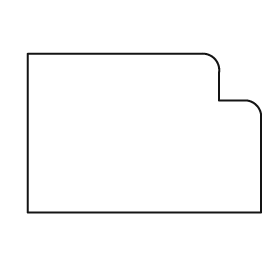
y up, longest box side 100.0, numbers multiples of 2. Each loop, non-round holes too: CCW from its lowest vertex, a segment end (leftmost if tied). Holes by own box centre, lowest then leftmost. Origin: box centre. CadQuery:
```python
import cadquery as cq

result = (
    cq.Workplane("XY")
    .moveTo(-50.0, -34.0)
    .lineTo(50.0, -34.0)
    .lineTo(50.0, 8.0)
    .threePointArc((48.0, 12.0), (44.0, 14.0))
    .lineTo(32.0, 14.0)
    .lineTo(32.0, 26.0)
    .threePointArc((30.0, 32.0), (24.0, 34.0))
    .lineTo(-50.0, 34.0)
    .close()
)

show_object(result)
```